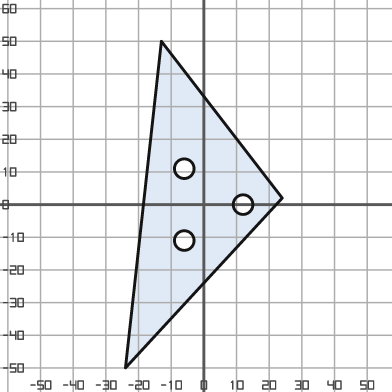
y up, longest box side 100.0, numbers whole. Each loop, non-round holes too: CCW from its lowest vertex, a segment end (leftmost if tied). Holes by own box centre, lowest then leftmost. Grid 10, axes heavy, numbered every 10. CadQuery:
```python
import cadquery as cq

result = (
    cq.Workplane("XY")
    .moveTo(-24.0, -50.0)
    .lineTo(24.0, 2.0)
    .lineTo(-13.0, 50.0)
    .close()
    .moveTo(-6.0, -11.0)
    .circle(3.0)
    .moveTo(12.0, 0.0)
    .circle(3.0)
    .moveTo(-6.0, 11.0)
    .circle(3.0)
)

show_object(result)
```